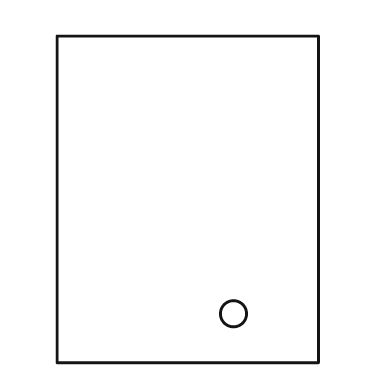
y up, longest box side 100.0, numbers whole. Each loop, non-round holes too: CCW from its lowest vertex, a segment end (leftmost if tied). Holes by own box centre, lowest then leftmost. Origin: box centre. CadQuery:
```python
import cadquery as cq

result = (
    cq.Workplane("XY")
    .moveTo(-40.0, -50.0)
    .lineTo(40.0, -50.0)
    .lineTo(40.0, 50.0)
    .lineTo(-40.0, 50.0)
    .close()
    .moveTo(14.0, -35.0)
    .circle(4.0)
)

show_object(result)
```